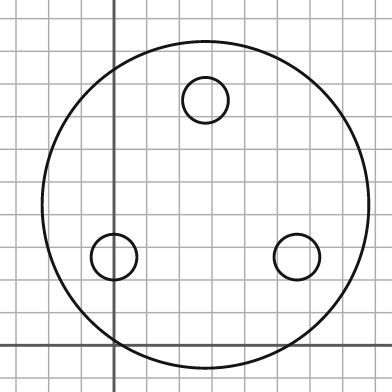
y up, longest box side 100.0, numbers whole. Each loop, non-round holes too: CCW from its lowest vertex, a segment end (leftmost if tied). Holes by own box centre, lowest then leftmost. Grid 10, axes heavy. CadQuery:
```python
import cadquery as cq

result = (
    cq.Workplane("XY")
    .moveTo(28.0, 43.0)
    .circle(50.0)
    .moveTo(0.0, 27.0)
    .circle(7.0)
    .moveTo(56.0, 27.0)
    .circle(7.0)
    .moveTo(28.0, 75.0)
    .circle(7.0)
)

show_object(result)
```